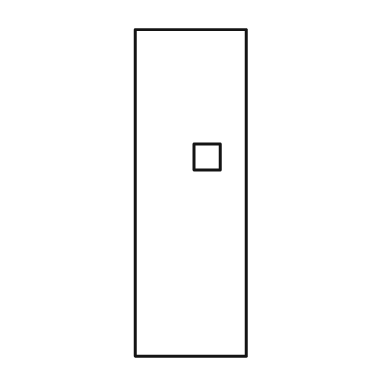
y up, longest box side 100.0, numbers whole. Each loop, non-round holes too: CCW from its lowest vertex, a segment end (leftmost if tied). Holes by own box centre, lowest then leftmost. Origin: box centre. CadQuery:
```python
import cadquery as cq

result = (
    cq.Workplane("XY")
    .moveTo(-17.0, -50.0)
    .lineTo(17.0, -50.0)
    .lineTo(17.0, 50.0)
    .lineTo(-17.0, 50.0)
    .close()
    .moveTo(1.0, 7.0)
    .lineTo(9.0, 7.0)
    .lineTo(9.0, 15.0)
    .lineTo(1.0, 15.0)
    .close()
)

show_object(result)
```